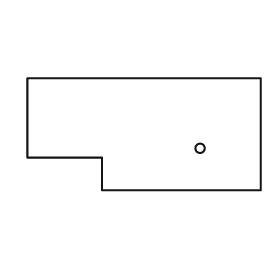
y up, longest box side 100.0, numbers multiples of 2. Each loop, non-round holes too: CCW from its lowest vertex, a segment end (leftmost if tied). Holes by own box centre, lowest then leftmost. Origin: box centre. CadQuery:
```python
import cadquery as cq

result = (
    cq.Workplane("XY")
    .moveTo(-18.0, -24.0)
    .lineTo(50.0, -24.0)
    .lineTo(50.0, 24.0)
    .lineTo(-50.0, 24.0)
    .lineTo(-50.0, -10.0)
    .lineTo(-18.0, -10.0)
    .close()
    .moveTo(24.0, -6.0)
    .circle(2.0)
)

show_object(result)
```